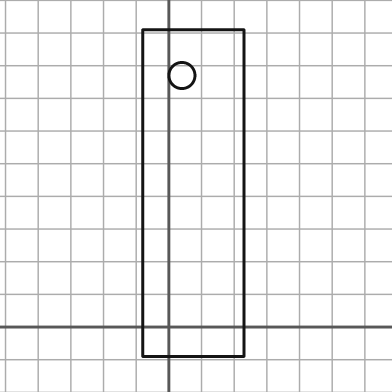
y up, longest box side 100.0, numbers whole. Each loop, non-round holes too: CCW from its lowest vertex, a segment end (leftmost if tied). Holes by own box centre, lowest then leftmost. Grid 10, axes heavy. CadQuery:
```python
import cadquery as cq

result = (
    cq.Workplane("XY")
    .moveTo(-8.0, -9.0)
    .lineTo(23.0, -9.0)
    .lineTo(23.0, 91.0)
    .lineTo(-8.0, 91.0)
    .close()
    .moveTo(4.0, 77.0)
    .circle(4.0)
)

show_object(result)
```